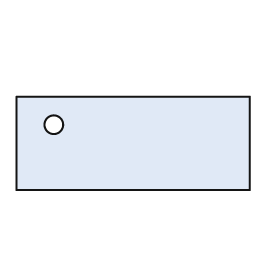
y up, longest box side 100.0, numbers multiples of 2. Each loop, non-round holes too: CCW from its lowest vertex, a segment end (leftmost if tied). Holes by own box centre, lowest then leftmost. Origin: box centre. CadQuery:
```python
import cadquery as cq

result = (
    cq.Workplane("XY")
    .moveTo(-50.0, -20.0)
    .lineTo(50.0, -20.0)
    .lineTo(50.0, 20.0)
    .lineTo(-50.0, 20.0)
    .close()
    .moveTo(-34.0, 8.0)
    .circle(4.0)
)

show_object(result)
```